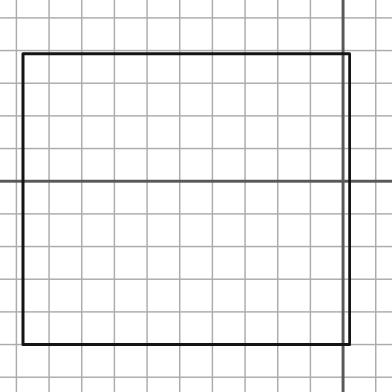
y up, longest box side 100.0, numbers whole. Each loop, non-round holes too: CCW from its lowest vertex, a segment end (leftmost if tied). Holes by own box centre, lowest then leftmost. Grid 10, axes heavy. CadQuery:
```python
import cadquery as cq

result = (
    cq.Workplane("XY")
    .moveTo(-98.0, -50.0)
    .lineTo(2.0, -50.0)
    .lineTo(2.0, 39.0)
    .lineTo(-98.0, 39.0)
    .close()
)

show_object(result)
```